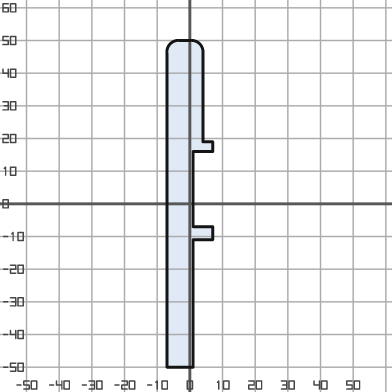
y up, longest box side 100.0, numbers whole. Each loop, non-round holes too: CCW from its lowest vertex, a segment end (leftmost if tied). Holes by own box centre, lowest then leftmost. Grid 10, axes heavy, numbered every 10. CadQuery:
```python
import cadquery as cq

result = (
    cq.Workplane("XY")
    .moveTo(-7.0, -50.0)
    .lineTo(1.0, -50.0)
    .lineTo(1.0, -11.0)
    .lineTo(7.0, -11.0)
    .lineTo(7.0, -7.0)
    .lineTo(1.0, -7.0)
    .lineTo(1.0, 16.0)
    .lineTo(7.0, 16.0)
    .lineTo(7.0, 19.0)
    .lineTo(4.0, 19.0)
    .lineTo(4.0, 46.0)
    .threePointArc((3.0, 49.0), (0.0, 50.0))
    .lineTo(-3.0, 50.0)
    .threePointArc((-6.0, 49.0), (-7.0, 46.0))
    .close()
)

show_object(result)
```